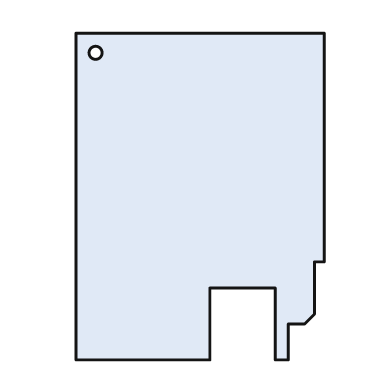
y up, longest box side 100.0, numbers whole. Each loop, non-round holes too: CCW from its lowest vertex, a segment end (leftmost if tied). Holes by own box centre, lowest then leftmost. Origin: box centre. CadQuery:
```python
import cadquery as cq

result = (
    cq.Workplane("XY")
    .moveTo(-38.0, -50.0)
    .lineTo(3.0, -50.0)
    .lineTo(3.0, -28.0)
    .lineTo(23.0, -28.0)
    .lineTo(23.0, -50.0)
    .lineTo(27.0, -50.0)
    .lineTo(27.0, -39.0)
    .lineTo(32.0, -39.0)
    .lineTo(35.0, -36.0)
    .lineTo(35.0, -20.0)
    .lineTo(38.0, -20.0)
    .lineTo(38.0, 50.0)
    .lineTo(-38.0, 50.0)
    .close()
    .moveTo(-32.0, 44.0)
    .circle(2.0)
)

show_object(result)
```